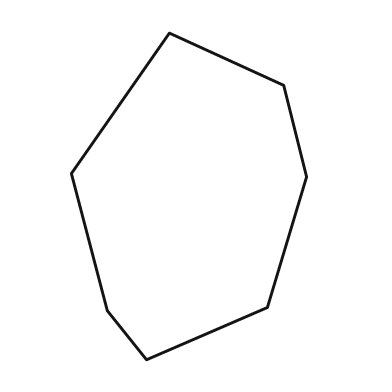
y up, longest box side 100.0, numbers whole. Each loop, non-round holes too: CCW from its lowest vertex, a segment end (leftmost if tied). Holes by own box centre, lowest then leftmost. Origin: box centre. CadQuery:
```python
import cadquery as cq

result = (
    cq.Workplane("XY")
    .moveTo(-13.0, -50.0)
    .lineTo(24.0, -34.0)
    .lineTo(36.0, 6.0)
    .lineTo(29.0, 34.0)
    .lineTo(-6.0, 50.0)
    .lineTo(-36.0, 7.0)
    .lineTo(-25.0, -35.0)
    .close()
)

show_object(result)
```